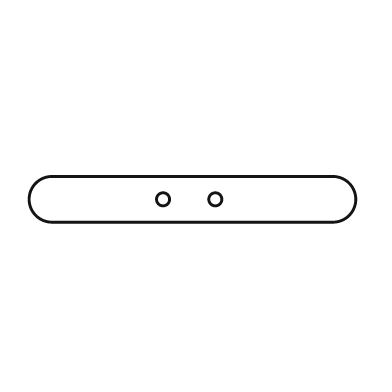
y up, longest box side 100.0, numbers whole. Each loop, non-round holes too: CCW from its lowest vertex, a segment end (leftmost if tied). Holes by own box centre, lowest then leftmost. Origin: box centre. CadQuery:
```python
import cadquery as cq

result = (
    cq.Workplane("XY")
    .moveTo(-43.0, -7.0)
    .lineTo(43.0, -7.0)
    .threePointArc((50.0, 0.0), (43.0, 7.0))
    .lineTo(-43.0, 7.0)
    .threePointArc((-50.0, 0.0), (-43.0, -7.0))
    .close()
    .moveTo(-9.0, 0.0)
    .circle(2.0)
    .moveTo(7.0, 0.0)
    .circle(2.0)
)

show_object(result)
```